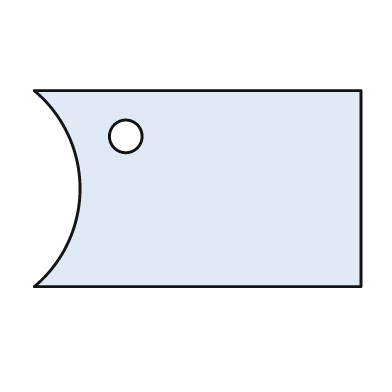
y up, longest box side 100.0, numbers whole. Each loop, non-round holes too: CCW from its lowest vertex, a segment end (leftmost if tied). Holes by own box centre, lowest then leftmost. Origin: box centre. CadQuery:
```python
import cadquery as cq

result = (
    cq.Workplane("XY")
    .moveTo(-50.0, -30.0)
    .lineTo(50.0, -30.0)
    .lineTo(50.0, 30.0)
    .lineTo(-50.0, 30.0)
    .threePointArc((-36.0, 0.0), (-50.0, -30.0))
    .close()
    .moveTo(-22.0, 16.0)
    .circle(5.0)
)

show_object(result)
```